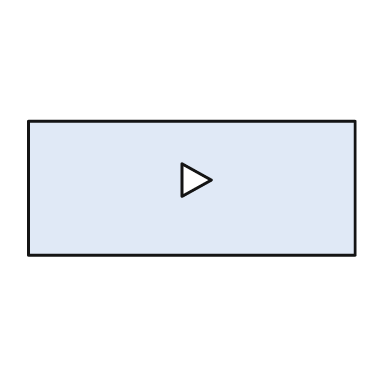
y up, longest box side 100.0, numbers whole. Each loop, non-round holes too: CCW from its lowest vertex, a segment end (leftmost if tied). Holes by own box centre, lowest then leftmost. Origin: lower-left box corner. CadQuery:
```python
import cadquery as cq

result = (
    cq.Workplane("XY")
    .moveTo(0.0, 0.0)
    .lineTo(100.0, 0.0)
    .lineTo(100.0, 41.0)
    .lineTo(0.0, 41.0)
    .close()
    .moveTo(47.0, 18.0)
    .lineTo(56.0, 23.0)
    .lineTo(47.0, 28.0)
    .close()
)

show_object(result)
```